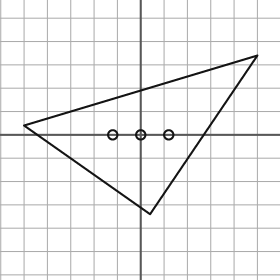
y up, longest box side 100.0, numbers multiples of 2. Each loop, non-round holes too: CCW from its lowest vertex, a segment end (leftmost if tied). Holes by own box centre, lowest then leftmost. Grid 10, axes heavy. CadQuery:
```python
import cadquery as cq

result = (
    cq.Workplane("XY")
    .moveTo(4.0, -34.0)
    .lineTo(50.0, 34.0)
    .lineTo(-50.0, 4.0)
    .close()
    .moveTo(-12.0, 0.0)
    .circle(2.0)
    .moveTo(0.0, 0.0)
    .circle(2.0)
    .moveTo(12.0, 0.0)
    .circle(2.0)
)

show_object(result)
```